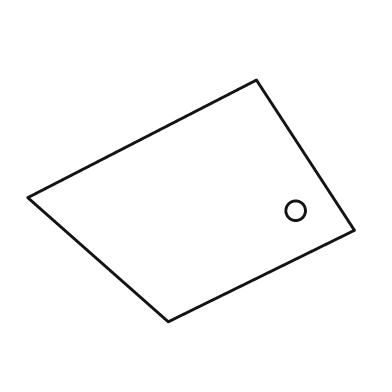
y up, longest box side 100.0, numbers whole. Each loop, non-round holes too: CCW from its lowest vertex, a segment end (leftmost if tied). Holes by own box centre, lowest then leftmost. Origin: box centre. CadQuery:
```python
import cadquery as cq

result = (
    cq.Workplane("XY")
    .moveTo(-7.0, -37.0)
    .lineTo(50.0, -9.0)
    .lineTo(20.0, 37.0)
    .lineTo(-50.0, 1.0)
    .close()
    .moveTo(32.0, -3.0)
    .circle(3.0)
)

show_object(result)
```